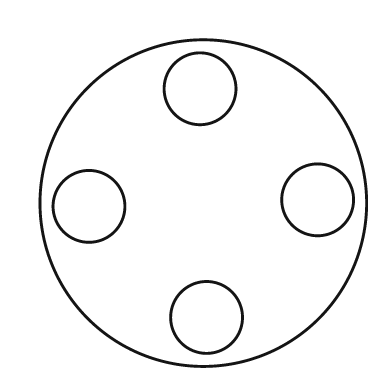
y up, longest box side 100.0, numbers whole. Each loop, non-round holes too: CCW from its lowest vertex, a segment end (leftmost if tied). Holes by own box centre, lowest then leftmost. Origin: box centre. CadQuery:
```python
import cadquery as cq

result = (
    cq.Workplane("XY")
    .moveTo(0.0, 0.0)
    .circle(50.0)
    .moveTo(1.0, -35.0)
    .circle(11.0)
    .moveTo(-35.0, -1.0)
    .circle(11.0)
    .moveTo(35.0, 1.0)
    .circle(11.0)
    .moveTo(-1.0, 35.0)
    .circle(11.0)
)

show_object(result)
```